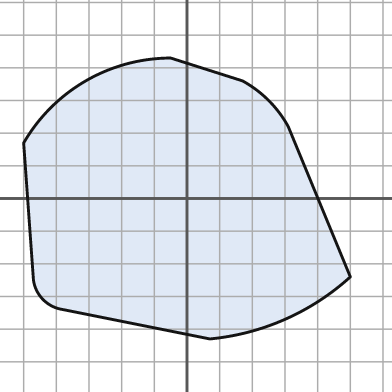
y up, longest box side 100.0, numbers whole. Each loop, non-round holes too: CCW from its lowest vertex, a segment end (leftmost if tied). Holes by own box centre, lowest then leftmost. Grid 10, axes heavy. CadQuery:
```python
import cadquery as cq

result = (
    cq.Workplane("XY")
    .moveTo(7.0, -43.0)
    .threePointArc((30.0, -37.0), (50.0, -24.0))
    .lineTo(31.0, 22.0)
    .threePointArc((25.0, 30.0), (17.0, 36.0))
    .lineTo(-5.0, 43.0)
    .threePointArc((-31.0, 36.0), (-50.0, 17.0))
    .lineTo(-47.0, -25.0)
    .threePointArc((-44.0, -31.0), (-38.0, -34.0))
    .close()
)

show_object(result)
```